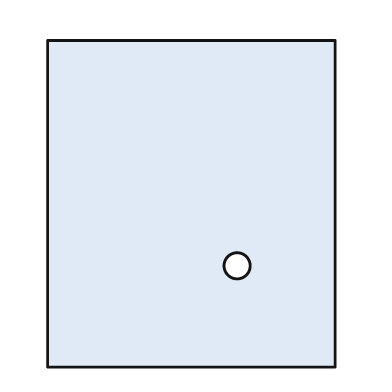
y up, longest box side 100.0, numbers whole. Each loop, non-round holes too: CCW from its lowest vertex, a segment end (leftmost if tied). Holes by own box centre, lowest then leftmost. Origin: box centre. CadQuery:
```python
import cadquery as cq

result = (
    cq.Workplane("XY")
    .moveTo(-44.0, -50.0)
    .lineTo(44.0, -50.0)
    .lineTo(44.0, 50.0)
    .lineTo(-44.0, 50.0)
    .close()
    .moveTo(14.0, -19.0)
    .circle(4.0)
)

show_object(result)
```